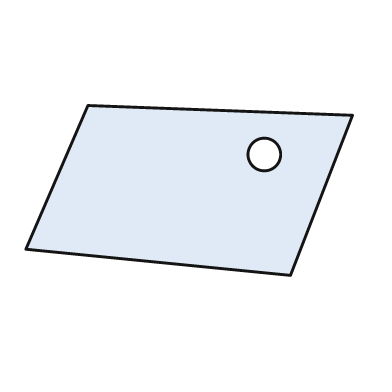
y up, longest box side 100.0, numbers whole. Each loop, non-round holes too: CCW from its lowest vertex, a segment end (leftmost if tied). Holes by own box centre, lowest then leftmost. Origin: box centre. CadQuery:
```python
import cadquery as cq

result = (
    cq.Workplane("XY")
    .moveTo(31.0, -26.0)
    .lineTo(50.0, 23.0)
    .lineTo(-31.0, 26.0)
    .lineTo(-50.0, -18.0)
    .close()
    .moveTo(23.0, 11.0)
    .circle(5.0)
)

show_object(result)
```